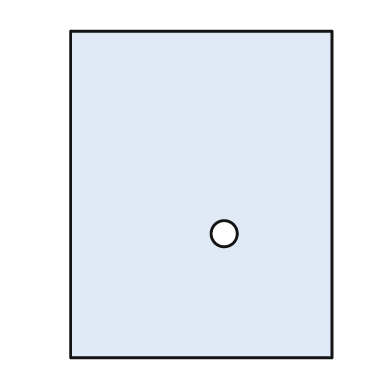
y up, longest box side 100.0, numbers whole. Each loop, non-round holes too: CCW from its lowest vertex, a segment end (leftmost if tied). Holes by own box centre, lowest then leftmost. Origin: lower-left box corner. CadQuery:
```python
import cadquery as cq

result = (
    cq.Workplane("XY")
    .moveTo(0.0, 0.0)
    .lineTo(80.0, 0.0)
    .lineTo(80.0, 100.0)
    .lineTo(0.0, 100.0)
    .close()
    .moveTo(47.0, 38.0)
    .circle(4.0)
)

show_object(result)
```